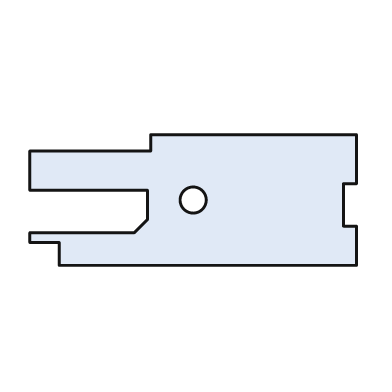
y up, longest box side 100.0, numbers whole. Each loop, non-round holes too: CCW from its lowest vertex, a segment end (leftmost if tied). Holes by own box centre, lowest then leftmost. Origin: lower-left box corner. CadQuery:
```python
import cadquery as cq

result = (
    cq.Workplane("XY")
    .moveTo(9.0, 0.0)
    .lineTo(100.0, 0.0)
    .lineTo(100.0, 12.0)
    .lineTo(96.0, 12.0)
    .lineTo(96.0, 25.0)
    .lineTo(100.0, 25.0)
    .lineTo(100.0, 40.0)
    .lineTo(37.0, 40.0)
    .lineTo(37.0, 35.0)
    .lineTo(0.0, 35.0)
    .lineTo(0.0, 23.0)
    .lineTo(36.0, 23.0)
    .lineTo(36.0, 14.0)
    .lineTo(32.0, 10.0)
    .lineTo(0.0, 10.0)
    .lineTo(0.0, 7.0)
    .lineTo(9.0, 7.0)
    .close()
    .moveTo(50.0, 20.0)
    .circle(4.0)
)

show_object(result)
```